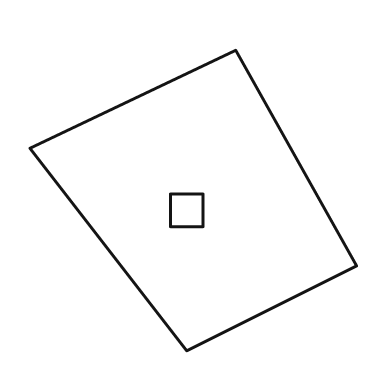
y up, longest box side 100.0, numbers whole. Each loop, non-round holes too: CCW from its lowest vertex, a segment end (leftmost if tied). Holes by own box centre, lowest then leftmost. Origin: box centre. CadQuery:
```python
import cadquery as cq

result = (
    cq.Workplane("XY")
    .moveTo(-2.0, -46.0)
    .lineTo(50.0, -20.0)
    .lineTo(13.0, 46.0)
    .lineTo(-50.0, 16.0)
    .close()
    .moveTo(-7.0, -8.0)
    .lineTo(3.0, -8.0)
    .lineTo(3.0, 2.0)
    .lineTo(-7.0, 2.0)
    .close()
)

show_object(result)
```